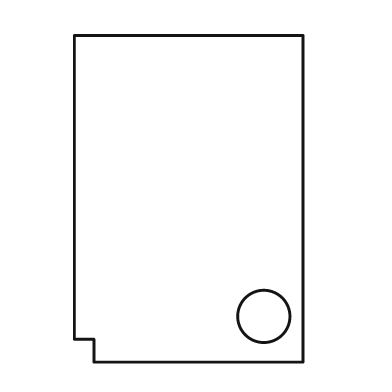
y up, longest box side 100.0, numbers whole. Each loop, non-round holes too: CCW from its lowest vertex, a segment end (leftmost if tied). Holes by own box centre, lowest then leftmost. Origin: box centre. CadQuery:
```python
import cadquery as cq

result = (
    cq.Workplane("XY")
    .moveTo(-29.0, -50.0)
    .lineTo(35.0, -50.0)
    .lineTo(35.0, 50.0)
    .lineTo(-35.0, 50.0)
    .lineTo(-35.0, -43.0)
    .lineTo(-29.0, -43.0)
    .close()
    .moveTo(23.0, -36.0)
    .circle(8.0)
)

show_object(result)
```